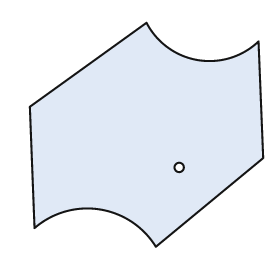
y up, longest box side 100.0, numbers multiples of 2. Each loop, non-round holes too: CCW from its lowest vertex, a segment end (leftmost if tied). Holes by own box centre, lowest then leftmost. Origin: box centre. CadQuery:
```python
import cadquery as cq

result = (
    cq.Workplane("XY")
    .moveTo(4.0, -48.0)
    .lineTo(50.0, -10.0)
    .lineTo(48.0, 40.0)
    .threePointArc((22.0, 32.0), (0.0, 48.0))
    .lineTo(-50.0, 12.0)
    .lineTo(-48.0, -40.0)
    .threePointArc((-20.0, -32.0), (4.0, -48.0))
    .close()
    .moveTo(14.0, -14.0)
    .circle(2.0)
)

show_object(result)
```